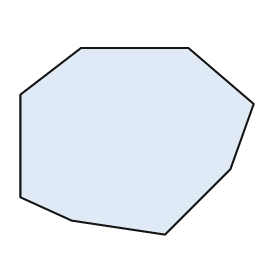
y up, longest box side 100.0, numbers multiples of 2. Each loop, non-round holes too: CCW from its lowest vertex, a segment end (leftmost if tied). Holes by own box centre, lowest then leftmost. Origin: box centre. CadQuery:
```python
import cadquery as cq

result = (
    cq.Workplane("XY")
    .moveTo(12.0, -40.0)
    .lineTo(40.0, -12.0)
    .lineTo(50.0, 16.0)
    .lineTo(22.0, 40.0)
    .lineTo(-24.0, 40.0)
    .lineTo(-50.0, 20.0)
    .lineTo(-50.0, -24.0)
    .lineTo(-28.0, -34.0)
    .close()
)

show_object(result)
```